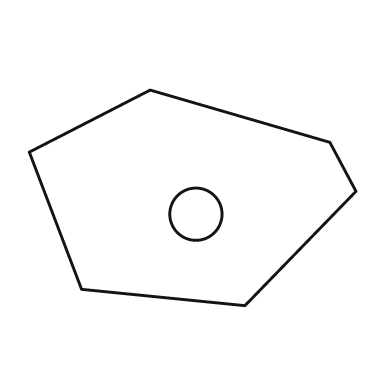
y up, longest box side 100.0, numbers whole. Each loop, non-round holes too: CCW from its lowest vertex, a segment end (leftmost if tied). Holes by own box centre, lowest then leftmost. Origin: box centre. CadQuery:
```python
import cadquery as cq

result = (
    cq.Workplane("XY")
    .moveTo(16.0, -33.0)
    .lineTo(50.0, 2.0)
    .lineTo(42.0, 17.0)
    .lineTo(-13.0, 33.0)
    .lineTo(-50.0, 14.0)
    .lineTo(-34.0, -28.0)
    .close()
    .moveTo(1.0, -5.0)
    .circle(8.0)
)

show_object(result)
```